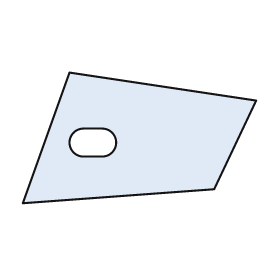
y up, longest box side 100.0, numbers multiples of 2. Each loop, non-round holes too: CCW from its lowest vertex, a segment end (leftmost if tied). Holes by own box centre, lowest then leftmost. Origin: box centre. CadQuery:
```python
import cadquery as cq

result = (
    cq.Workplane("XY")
    .moveTo(-50.0, -28.0)
    .lineTo(32.0, -22.0)
    .lineTo(50.0, 16.0)
    .lineTo(-30.0, 28.0)
    .close()
    .moveTo(-24.0, -8.0)
    .lineTo(-16.0, -8.0)
    .threePointArc((-10.0, -2.0), (-16.0, 4.0))
    .lineTo(-24.0, 4.0)
    .threePointArc((-30.0, -2.0), (-24.0, -8.0))
    .close()
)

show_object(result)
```